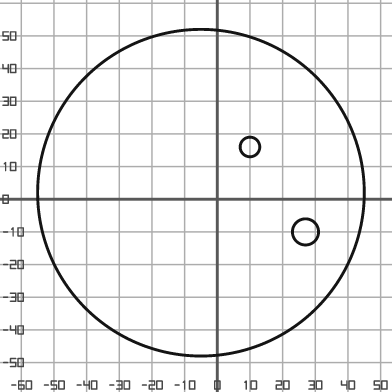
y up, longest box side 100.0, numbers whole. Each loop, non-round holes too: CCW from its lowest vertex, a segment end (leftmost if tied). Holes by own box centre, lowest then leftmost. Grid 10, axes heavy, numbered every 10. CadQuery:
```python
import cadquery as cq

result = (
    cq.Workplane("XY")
    .moveTo(-5.0, 2.0)
    .circle(50.0)
    .moveTo(27.0, -10.0)
    .circle(4.0)
    .moveTo(10.0, 16.0)
    .circle(3.0)
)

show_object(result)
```